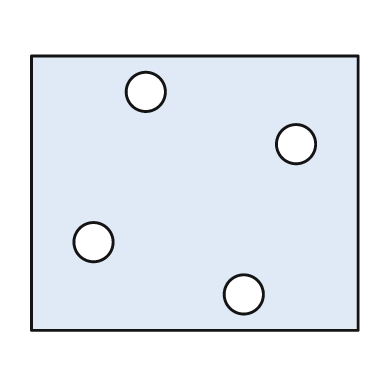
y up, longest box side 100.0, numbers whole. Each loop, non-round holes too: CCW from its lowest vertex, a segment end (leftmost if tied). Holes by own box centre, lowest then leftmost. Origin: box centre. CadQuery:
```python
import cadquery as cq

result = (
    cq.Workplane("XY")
    .moveTo(-50.0, -42.0)
    .lineTo(50.0, -42.0)
    .lineTo(50.0, 42.0)
    .lineTo(-50.0, 42.0)
    .close()
    .moveTo(15.0, -31.0)
    .circle(6.0)
    .moveTo(-31.0, -15.0)
    .circle(6.0)
    .moveTo(31.0, 15.0)
    .circle(6.0)
    .moveTo(-15.0, 31.0)
    .circle(6.0)
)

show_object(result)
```